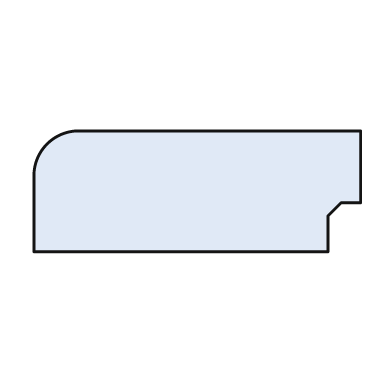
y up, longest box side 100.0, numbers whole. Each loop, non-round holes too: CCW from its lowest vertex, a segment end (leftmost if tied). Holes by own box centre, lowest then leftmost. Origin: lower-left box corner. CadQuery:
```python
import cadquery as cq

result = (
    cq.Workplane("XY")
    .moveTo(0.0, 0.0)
    .lineTo(90.0, 0.0)
    .lineTo(90.0, 11.0)
    .lineTo(94.0, 15.0)
    .lineTo(100.0, 15.0)
    .lineTo(100.0, 37.0)
    .lineTo(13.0, 37.0)
    .threePointArc((4.0, 33.0), (0.0, 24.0))
    .close()
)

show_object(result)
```